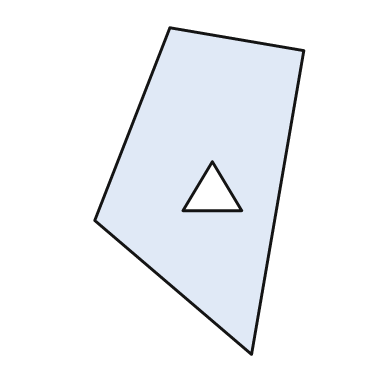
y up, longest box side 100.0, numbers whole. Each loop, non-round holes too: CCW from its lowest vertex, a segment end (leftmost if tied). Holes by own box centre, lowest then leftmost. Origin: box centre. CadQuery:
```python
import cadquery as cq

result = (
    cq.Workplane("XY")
    .moveTo(16.0, -50.0)
    .lineTo(32.0, 43.0)
    .lineTo(-9.0, 50.0)
    .lineTo(-32.0, -9.0)
    .close()
    .moveTo(-5.0, -6.0)
    .lineTo(13.0, -6.0)
    .lineTo(4.0, 9.0)
    .close()
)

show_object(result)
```